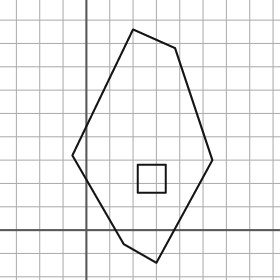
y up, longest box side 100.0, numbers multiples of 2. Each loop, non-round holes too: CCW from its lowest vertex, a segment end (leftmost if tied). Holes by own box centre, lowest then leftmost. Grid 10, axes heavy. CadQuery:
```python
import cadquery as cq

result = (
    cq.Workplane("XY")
    .moveTo(30.0, -14.0)
    .lineTo(54.0, 30.0)
    .lineTo(38.0, 78.0)
    .lineTo(20.0, 86.0)
    .lineTo(-6.0, 32.0)
    .lineTo(16.0, -6.0)
    .close()
    .moveTo(22.0, 16.0)
    .lineTo(34.0, 16.0)
    .lineTo(34.0, 28.0)
    .lineTo(22.0, 28.0)
    .close()
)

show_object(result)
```